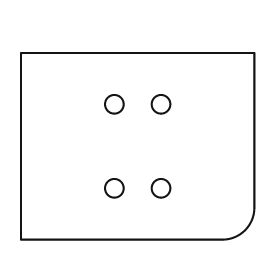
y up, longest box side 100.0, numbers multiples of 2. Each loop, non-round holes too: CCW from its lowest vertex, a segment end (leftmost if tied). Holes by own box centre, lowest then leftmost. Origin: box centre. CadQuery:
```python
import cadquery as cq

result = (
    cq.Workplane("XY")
    .moveTo(-50.0, -40.0)
    .lineTo(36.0, -40.0)
    .threePointArc((46.0, -36.0), (50.0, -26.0))
    .lineTo(50.0, 40.0)
    .lineTo(-50.0, 40.0)
    .close()
    .moveTo(-10.0, -18.0)
    .circle(4.0)
    .moveTo(10.0, -18.0)
    .circle(4.0)
    .moveTo(-10.0, 18.0)
    .circle(4.0)
    .moveTo(10.0, 18.0)
    .circle(4.0)
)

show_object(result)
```